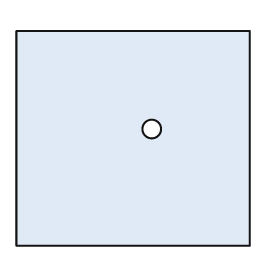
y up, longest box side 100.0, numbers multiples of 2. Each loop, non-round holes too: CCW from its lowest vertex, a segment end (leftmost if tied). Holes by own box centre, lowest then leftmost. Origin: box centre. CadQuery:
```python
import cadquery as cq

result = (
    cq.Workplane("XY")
    .moveTo(-50.0, -46.0)
    .lineTo(50.0, -46.0)
    .lineTo(50.0, 46.0)
    .lineTo(-50.0, 46.0)
    .close()
    .moveTo(8.0, 4.0)
    .circle(4.0)
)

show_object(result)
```